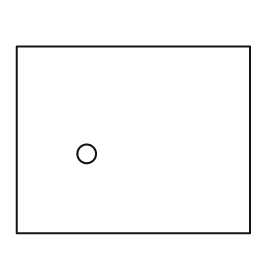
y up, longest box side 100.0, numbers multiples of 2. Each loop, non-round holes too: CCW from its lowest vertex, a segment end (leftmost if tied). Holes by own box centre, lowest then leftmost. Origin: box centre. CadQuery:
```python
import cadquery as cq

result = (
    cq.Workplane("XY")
    .moveTo(-50.0, -40.0)
    .lineTo(50.0, -40.0)
    .lineTo(50.0, 40.0)
    .lineTo(-50.0, 40.0)
    .close()
    .moveTo(-20.0, -6.0)
    .circle(4.0)
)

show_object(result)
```